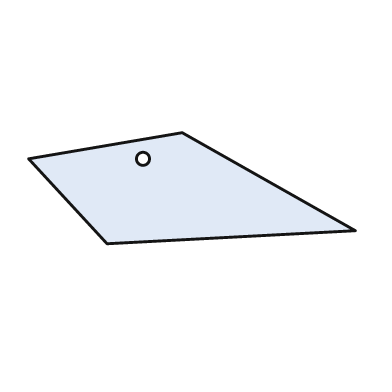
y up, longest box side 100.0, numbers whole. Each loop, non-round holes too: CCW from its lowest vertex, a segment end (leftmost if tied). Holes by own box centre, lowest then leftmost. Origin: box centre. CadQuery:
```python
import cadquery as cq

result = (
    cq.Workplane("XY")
    .moveTo(-26.0, -17.0)
    .lineTo(50.0, -13.0)
    .lineTo(-3.0, 17.0)
    .lineTo(-50.0, 9.0)
    .close()
    .moveTo(-15.0, 9.0)
    .circle(2.0)
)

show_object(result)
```